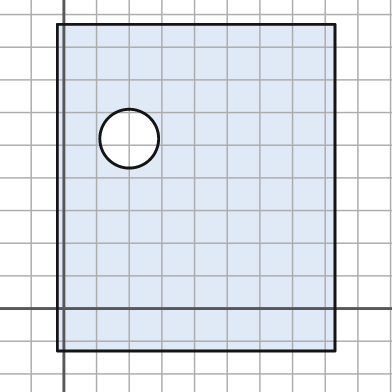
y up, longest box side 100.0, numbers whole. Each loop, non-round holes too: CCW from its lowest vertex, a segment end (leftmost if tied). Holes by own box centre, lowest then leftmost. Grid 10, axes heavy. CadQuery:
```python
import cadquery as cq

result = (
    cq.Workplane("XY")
    .moveTo(-2.0, -13.0)
    .lineTo(83.0, -13.0)
    .lineTo(83.0, 87.0)
    .lineTo(-2.0, 87.0)
    .close()
    .moveTo(20.0, 52.0)
    .circle(9.0)
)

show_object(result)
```